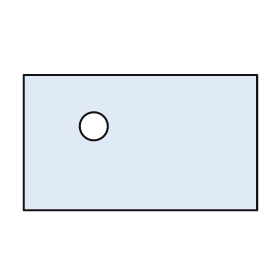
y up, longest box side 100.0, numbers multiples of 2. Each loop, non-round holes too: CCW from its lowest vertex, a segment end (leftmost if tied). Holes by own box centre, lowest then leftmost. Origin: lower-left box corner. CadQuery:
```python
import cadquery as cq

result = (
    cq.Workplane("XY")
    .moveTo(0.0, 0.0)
    .lineTo(100.0, 0.0)
    .lineTo(100.0, 58.0)
    .lineTo(0.0, 58.0)
    .close()
    .moveTo(30.0, 36.0)
    .circle(6.0)
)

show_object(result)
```